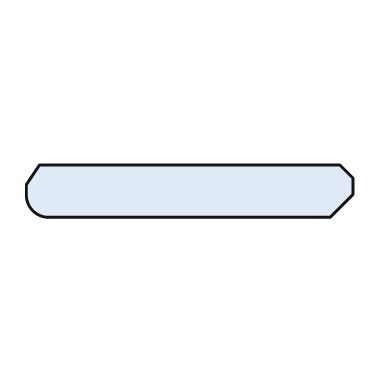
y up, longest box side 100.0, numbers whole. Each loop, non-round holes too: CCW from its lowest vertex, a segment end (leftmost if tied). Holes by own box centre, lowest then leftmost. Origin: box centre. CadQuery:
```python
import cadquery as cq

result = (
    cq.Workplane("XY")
    .moveTo(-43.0, -8.0)
    .lineTo(43.0, -8.0)
    .lineTo(50.0, -1.0)
    .lineTo(50.0, 4.0)
    .lineTo(46.0, 8.0)
    .lineTo(-46.0, 8.0)
    .lineTo(-50.0, 2.0)
    .lineTo(-50.0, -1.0)
    .threePointArc((-48.0, -6.0), (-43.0, -8.0))
    .close()
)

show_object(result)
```